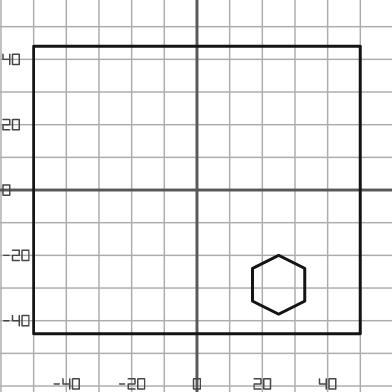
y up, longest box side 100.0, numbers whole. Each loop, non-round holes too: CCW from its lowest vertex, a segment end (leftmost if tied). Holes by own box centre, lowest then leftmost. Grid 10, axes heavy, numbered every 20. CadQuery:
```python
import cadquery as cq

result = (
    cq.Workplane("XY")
    .moveTo(-50.0, -44.0)
    .lineTo(50.0, -44.0)
    .lineTo(50.0, 44.0)
    .lineTo(-50.0, 44.0)
    .close()
    .moveTo(25.0, -38.0)
    .lineTo(33.0, -34.0)
    .lineTo(33.0, -24.0)
    .lineTo(25.0, -20.0)
    .lineTo(17.0, -24.0)
    .lineTo(17.0, -34.0)
    .close()
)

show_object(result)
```